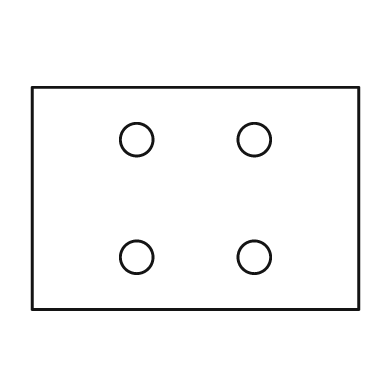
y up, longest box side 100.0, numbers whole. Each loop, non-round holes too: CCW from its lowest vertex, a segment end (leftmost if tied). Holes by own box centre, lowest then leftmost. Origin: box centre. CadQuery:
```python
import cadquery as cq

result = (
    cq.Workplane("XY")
    .moveTo(-50.0, -34.0)
    .lineTo(50.0, -34.0)
    .lineTo(50.0, 34.0)
    .lineTo(-50.0, 34.0)
    .close()
    .moveTo(-18.0, -18.0)
    .circle(5.0)
    .moveTo(18.0, -18.0)
    .circle(5.0)
    .moveTo(-18.0, 18.0)
    .circle(5.0)
    .moveTo(18.0, 18.0)
    .circle(5.0)
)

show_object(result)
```